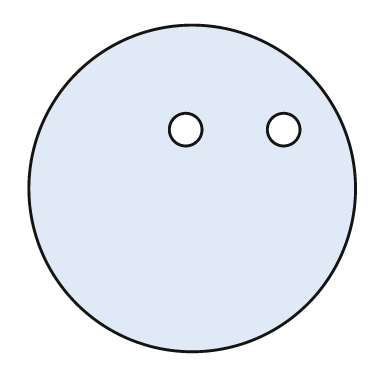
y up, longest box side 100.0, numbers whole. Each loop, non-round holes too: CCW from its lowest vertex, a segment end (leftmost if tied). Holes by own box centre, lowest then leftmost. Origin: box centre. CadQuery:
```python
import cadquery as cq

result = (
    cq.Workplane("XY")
    .moveTo(0.0, 0.0)
    .circle(50.0)
    .moveTo(-2.0, 18.0)
    .circle(5.0)
    .moveTo(28.0, 18.0)
    .circle(5.0)
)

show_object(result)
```